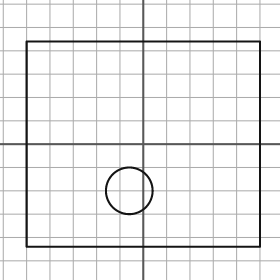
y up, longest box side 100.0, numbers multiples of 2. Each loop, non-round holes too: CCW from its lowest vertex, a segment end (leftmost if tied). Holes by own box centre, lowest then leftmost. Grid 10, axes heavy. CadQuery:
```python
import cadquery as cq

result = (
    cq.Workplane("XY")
    .moveTo(-50.0, -44.0)
    .lineTo(50.0, -44.0)
    .lineTo(50.0, 44.0)
    .lineTo(-50.0, 44.0)
    .close()
    .moveTo(-6.0, -20.0)
    .circle(10.0)
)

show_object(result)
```